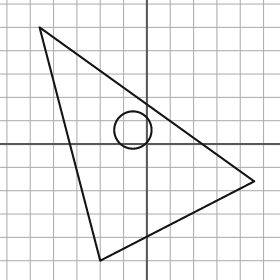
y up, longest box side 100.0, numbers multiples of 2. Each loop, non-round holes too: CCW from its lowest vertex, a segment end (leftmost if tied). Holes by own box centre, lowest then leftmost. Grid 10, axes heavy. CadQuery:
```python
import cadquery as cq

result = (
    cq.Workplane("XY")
    .moveTo(-20.0, -50.0)
    .lineTo(46.0, -16.0)
    .lineTo(-46.0, 50.0)
    .close()
    .moveTo(-6.0, 6.0)
    .circle(8.0)
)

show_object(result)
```